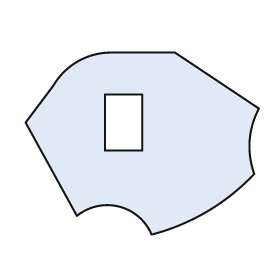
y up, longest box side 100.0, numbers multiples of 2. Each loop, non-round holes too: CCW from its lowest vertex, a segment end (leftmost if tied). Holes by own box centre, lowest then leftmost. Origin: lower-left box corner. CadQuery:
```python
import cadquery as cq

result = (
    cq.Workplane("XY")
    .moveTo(54.0, 0.0)
    .threePointArc((78.0, 10.0), (98.0, 26.0))
    .threePointArc((96.0, 40.0), (100.0, 54.0))
    .lineTo(64.0, 78.0)
    .lineTo(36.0, 78.0)
    .threePointArc((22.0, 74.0), (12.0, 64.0))
    .lineTo(0.0, 48.0)
    .lineTo(22.0, 8.0)
    .threePointArc((40.0, 12.0), (54.0, 0.0))
    .close()
    .moveTo(34.0, 36.0)
    .lineTo(50.0, 36.0)
    .lineTo(50.0, 60.0)
    .lineTo(34.0, 60.0)
    .close()
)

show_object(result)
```